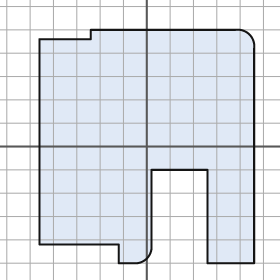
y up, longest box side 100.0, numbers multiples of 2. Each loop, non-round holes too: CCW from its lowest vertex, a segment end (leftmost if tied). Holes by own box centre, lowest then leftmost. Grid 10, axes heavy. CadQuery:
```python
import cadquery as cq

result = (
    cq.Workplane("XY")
    .moveTo(-12.0, -50.0)
    .lineTo(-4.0, -50.0)
    .threePointArc((0.0, -48.0), (2.0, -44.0))
    .lineTo(2.0, -10.0)
    .lineTo(26.0, -10.0)
    .lineTo(26.0, -50.0)
    .lineTo(46.0, -50.0)
    .lineTo(46.0, 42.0)
    .threePointArc((44.0, 48.0), (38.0, 50.0))
    .lineTo(-24.0, 50.0)
    .lineTo(-24.0, 46.0)
    .lineTo(-46.0, 46.0)
    .lineTo(-46.0, -42.0)
    .lineTo(-12.0, -42.0)
    .close()
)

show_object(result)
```